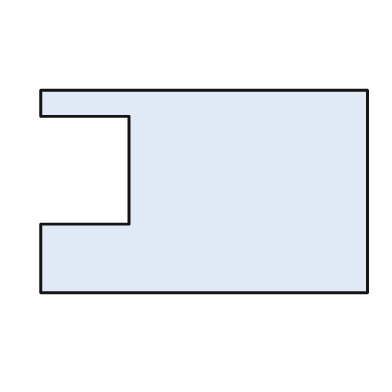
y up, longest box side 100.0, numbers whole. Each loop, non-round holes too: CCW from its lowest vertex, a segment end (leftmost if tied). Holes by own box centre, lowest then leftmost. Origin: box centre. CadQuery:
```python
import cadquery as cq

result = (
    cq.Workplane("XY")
    .moveTo(-50.0, -31.0)
    .lineTo(50.0, -31.0)
    .lineTo(50.0, 31.0)
    .lineTo(-50.0, 31.0)
    .lineTo(-50.0, 23.0)
    .lineTo(-23.0, 23.0)
    .lineTo(-23.0, -10.0)
    .lineTo(-50.0, -10.0)
    .close()
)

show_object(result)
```